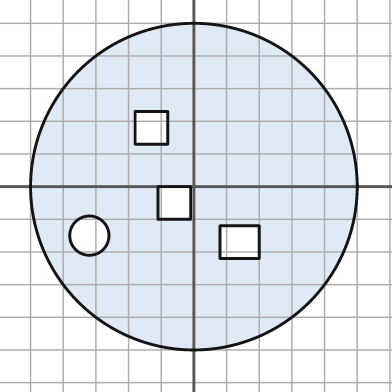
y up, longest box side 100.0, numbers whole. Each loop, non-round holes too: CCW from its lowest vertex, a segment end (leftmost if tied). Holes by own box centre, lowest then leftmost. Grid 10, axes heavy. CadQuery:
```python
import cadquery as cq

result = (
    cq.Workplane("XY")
    .moveTo(0.0, 0.0)
    .circle(50.0)
    .moveTo(8.0, -22.0)
    .lineTo(20.0, -22.0)
    .lineTo(20.0, -12.0)
    .lineTo(8.0, -12.0)
    .close()
    .moveTo(-32.0, -15.0)
    .circle(6.0)
    .moveTo(-11.0, -10.0)
    .lineTo(-1.0, -10.0)
    .lineTo(-1.0, 0.0)
    .lineTo(-11.0, 0.0)
    .close()
    .moveTo(-18.0, 13.0)
    .lineTo(-8.0, 13.0)
    .lineTo(-8.0, 23.0)
    .lineTo(-18.0, 23.0)
    .close()
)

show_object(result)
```